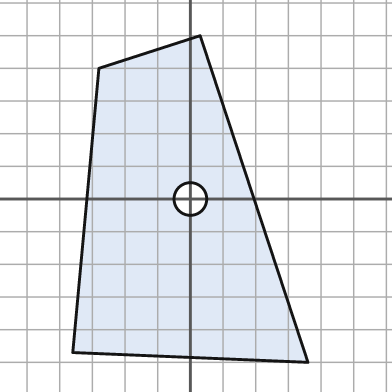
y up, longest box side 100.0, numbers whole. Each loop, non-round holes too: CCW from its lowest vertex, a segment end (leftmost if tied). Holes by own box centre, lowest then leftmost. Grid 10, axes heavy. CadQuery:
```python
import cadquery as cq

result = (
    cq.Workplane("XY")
    .moveTo(36.0, -50.0)
    .lineTo(3.0, 50.0)
    .lineTo(-28.0, 40.0)
    .lineTo(-36.0, -47.0)
    .close()
    .moveTo(0.0, 0.0)
    .circle(5.0)
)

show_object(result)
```